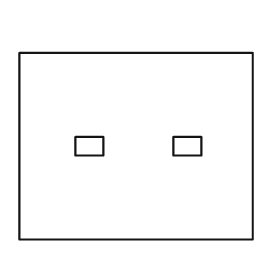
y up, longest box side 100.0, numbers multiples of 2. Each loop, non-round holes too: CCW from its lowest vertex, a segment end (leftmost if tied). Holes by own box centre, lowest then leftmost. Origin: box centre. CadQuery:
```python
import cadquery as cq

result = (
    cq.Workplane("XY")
    .moveTo(-50.0, -40.0)
    .lineTo(50.0, -40.0)
    .lineTo(50.0, 40.0)
    .lineTo(-50.0, 40.0)
    .close()
    .moveTo(-26.0, -4.0)
    .lineTo(-14.0, -4.0)
    .lineTo(-14.0, 4.0)
    .lineTo(-26.0, 4.0)
    .close()
    .moveTo(16.0, -4.0)
    .lineTo(28.0, -4.0)
    .lineTo(28.0, 4.0)
    .lineTo(16.0, 4.0)
    .close()
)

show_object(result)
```